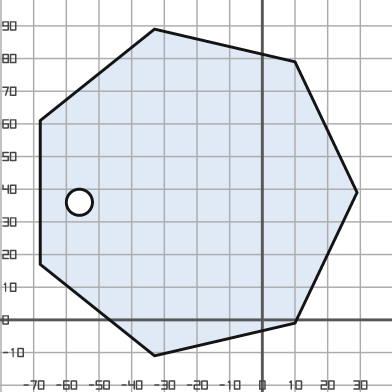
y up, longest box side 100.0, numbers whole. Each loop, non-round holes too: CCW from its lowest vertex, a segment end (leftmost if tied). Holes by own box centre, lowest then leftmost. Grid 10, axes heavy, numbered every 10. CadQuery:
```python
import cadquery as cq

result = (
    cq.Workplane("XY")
    .moveTo(-33.0, -11.0)
    .lineTo(10.0, -1.0)
    .lineTo(29.0, 39.0)
    .lineTo(10.0, 79.0)
    .lineTo(-33.0, 89.0)
    .lineTo(-68.0, 61.0)
    .lineTo(-68.0, 17.0)
    .close()
    .moveTo(-56.0, 36.0)
    .circle(4.0)
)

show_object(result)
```